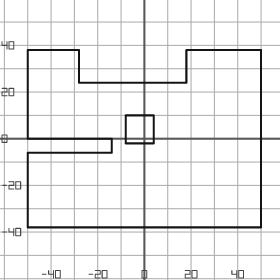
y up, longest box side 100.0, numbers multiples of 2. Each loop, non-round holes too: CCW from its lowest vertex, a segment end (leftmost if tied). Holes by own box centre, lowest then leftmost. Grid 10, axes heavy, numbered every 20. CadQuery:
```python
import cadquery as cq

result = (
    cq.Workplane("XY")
    .moveTo(-50.0, -38.0)
    .lineTo(50.0, -38.0)
    .lineTo(50.0, 38.0)
    .lineTo(18.0, 38.0)
    .lineTo(18.0, 24.0)
    .lineTo(-28.0, 24.0)
    .lineTo(-28.0, 38.0)
    .lineTo(-50.0, 38.0)
    .lineTo(-50.0, 0.0)
    .lineTo(-14.0, 0.0)
    .lineTo(-14.0, -6.0)
    .lineTo(-50.0, -6.0)
    .close()
    .moveTo(-8.0, -2.0)
    .lineTo(4.0, -2.0)
    .lineTo(4.0, 10.0)
    .lineTo(-8.0, 10.0)
    .close()
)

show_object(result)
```